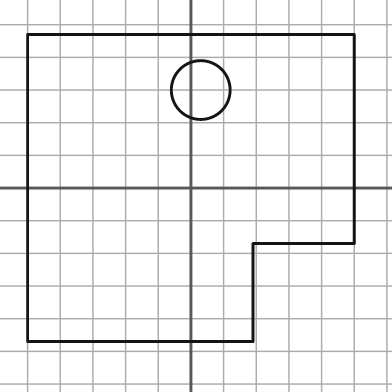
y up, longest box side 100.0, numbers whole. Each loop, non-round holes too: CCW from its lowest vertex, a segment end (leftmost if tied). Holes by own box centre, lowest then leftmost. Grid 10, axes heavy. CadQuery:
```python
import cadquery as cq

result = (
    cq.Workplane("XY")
    .moveTo(-50.0, -47.0)
    .lineTo(19.0, -47.0)
    .lineTo(19.0, -17.0)
    .lineTo(50.0, -17.0)
    .lineTo(50.0, 47.0)
    .lineTo(-50.0, 47.0)
    .close()
    .moveTo(3.0, 30.0)
    .circle(9.0)
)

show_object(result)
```